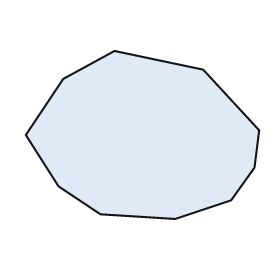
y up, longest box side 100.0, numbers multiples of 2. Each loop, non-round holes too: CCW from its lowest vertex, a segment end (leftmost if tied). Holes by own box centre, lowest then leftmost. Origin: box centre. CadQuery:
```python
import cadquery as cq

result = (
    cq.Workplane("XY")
    .moveTo(14.0, -36.0)
    .lineTo(38.0, -28.0)
    .lineTo(48.0, -14.0)
    .lineTo(50.0, 2.0)
    .lineTo(26.0, 28.0)
    .lineTo(-12.0, 36.0)
    .lineTo(-34.0, 24.0)
    .lineTo(-50.0, 0.0)
    .lineTo(-36.0, -22.0)
    .lineTo(-18.0, -34.0)
    .close()
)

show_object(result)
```